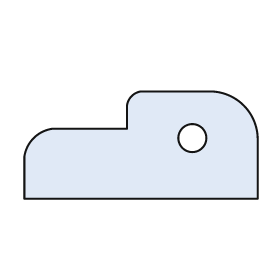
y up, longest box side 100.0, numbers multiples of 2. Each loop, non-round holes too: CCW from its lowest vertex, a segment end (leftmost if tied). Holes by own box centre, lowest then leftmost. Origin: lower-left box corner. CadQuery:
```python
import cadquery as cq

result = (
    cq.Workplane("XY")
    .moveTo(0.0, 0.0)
    .lineTo(100.0, 0.0)
    .lineTo(100.0, 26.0)
    .threePointArc((94.0, 40.0), (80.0, 46.0))
    .lineTo(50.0, 46.0)
    .threePointArc((46.0, 44.0), (44.0, 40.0))
    .lineTo(44.0, 30.0)
    .lineTo(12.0, 30.0)
    .threePointArc((4.0, 26.0), (0.0, 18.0))
    .close()
    .moveTo(72.0, 26.0)
    .circle(6.0)
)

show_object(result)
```